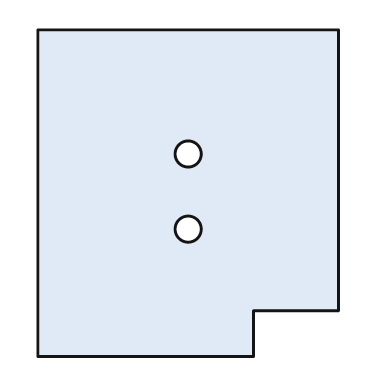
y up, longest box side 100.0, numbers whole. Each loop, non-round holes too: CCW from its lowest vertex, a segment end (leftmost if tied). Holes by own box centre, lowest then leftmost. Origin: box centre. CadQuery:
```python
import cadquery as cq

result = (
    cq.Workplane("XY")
    .moveTo(-46.0, -50.0)
    .lineTo(20.0, -50.0)
    .lineTo(20.0, -36.0)
    .lineTo(46.0, -36.0)
    .lineTo(46.0, 50.0)
    .lineTo(-46.0, 50.0)
    .close()
    .moveTo(0.0, -11.0)
    .circle(4.0)
    .moveTo(0.0, 12.0)
    .circle(4.0)
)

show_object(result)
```